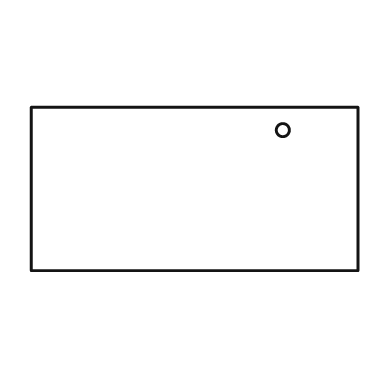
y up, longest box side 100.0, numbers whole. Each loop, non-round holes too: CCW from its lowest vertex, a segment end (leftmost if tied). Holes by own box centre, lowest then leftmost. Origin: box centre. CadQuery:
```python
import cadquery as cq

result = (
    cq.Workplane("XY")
    .moveTo(-50.0, -25.0)
    .lineTo(50.0, -25.0)
    .lineTo(50.0, 25.0)
    .lineTo(-50.0, 25.0)
    .close()
    .moveTo(27.0, 18.0)
    .circle(2.0)
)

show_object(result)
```